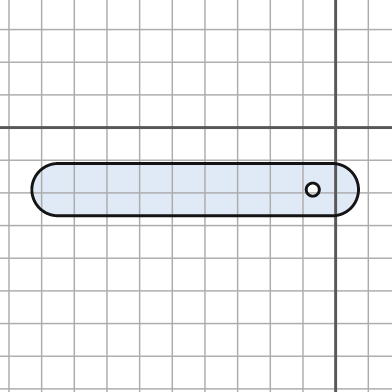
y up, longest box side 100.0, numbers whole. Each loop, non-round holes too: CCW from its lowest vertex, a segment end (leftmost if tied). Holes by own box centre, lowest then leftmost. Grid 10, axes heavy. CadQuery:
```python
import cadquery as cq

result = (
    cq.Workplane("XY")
    .moveTo(-85.0, -27.0)
    .lineTo(-1.0, -27.0)
    .threePointArc((7.0, -19.0), (-1.0, -11.0))
    .lineTo(-85.0, -11.0)
    .threePointArc((-93.0, -19.0), (-85.0, -27.0))
    .close()
    .moveTo(-7.0, -19.0)
    .circle(2.0)
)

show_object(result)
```